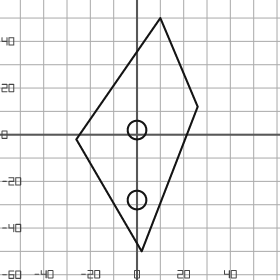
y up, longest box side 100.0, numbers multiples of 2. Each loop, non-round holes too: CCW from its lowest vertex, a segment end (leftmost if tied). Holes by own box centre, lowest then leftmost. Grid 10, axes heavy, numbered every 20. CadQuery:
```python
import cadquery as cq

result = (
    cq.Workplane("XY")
    .moveTo(2.0, -50.0)
    .lineTo(26.0, 12.0)
    .lineTo(10.0, 50.0)
    .lineTo(-26.0, -2.0)
    .close()
    .moveTo(0.0, -28.0)
    .circle(4.0)
    .moveTo(0.0, 2.0)
    .circle(4.0)
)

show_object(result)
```